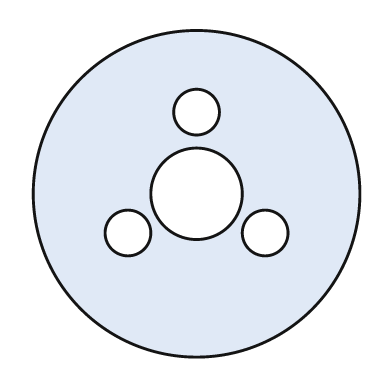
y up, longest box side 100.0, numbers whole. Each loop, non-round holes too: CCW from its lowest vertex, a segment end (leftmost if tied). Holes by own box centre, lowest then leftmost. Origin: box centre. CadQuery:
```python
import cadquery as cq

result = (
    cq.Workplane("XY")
    .moveTo(0.0, 0.0)
    .circle(50.0)
    .moveTo(-21.0, -12.0)
    .circle(7.0)
    .moveTo(21.0, -12.0)
    .circle(7.0)
    .moveTo(0.0, 0.0)
    .circle(14.0)
    .moveTo(0.0, 25.0)
    .circle(7.0)
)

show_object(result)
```